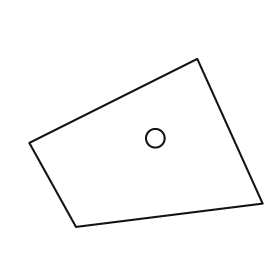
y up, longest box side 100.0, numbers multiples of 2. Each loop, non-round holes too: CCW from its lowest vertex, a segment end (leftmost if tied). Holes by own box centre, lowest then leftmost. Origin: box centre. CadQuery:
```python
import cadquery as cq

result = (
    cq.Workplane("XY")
    .moveTo(-30.0, -36.0)
    .lineTo(50.0, -26.0)
    .lineTo(22.0, 36.0)
    .lineTo(-50.0, 0.0)
    .close()
    .moveTo(4.0, 2.0)
    .circle(4.0)
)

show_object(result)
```